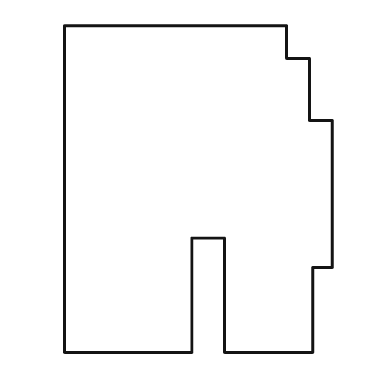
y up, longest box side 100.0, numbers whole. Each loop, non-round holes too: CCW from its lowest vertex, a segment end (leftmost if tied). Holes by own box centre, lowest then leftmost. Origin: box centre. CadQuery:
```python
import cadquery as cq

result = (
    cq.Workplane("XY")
    .moveTo(-41.0, -50.0)
    .lineTo(-2.0, -50.0)
    .lineTo(-2.0, -15.0)
    .lineTo(8.0, -15.0)
    .lineTo(8.0, -50.0)
    .lineTo(35.0, -50.0)
    .lineTo(35.0, -24.0)
    .lineTo(41.0, -24.0)
    .lineTo(41.0, 21.0)
    .lineTo(34.0, 21.0)
    .lineTo(34.0, 40.0)
    .lineTo(27.0, 40.0)
    .lineTo(27.0, 50.0)
    .lineTo(-41.0, 50.0)
    .close()
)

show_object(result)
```